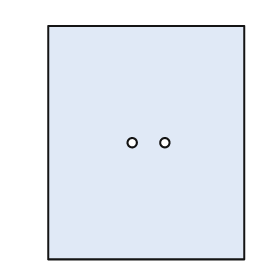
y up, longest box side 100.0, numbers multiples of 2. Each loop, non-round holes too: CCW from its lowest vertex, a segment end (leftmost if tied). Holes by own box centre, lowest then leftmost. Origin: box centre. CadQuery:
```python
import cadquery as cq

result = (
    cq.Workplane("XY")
    .moveTo(-42.0, -50.0)
    .lineTo(42.0, -50.0)
    .lineTo(42.0, 50.0)
    .lineTo(-42.0, 50.0)
    .close()
    .moveTo(-6.0, 0.0)
    .circle(2.0)
    .moveTo(8.0, 0.0)
    .circle(2.0)
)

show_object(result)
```